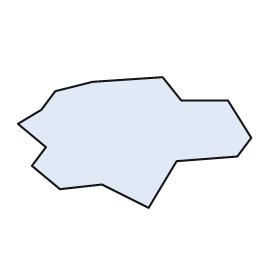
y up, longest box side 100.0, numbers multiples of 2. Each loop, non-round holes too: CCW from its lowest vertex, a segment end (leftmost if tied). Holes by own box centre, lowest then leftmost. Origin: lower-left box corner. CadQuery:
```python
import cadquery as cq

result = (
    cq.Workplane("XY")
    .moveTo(56.0, 0.0)
    .lineTo(68.0, 20.0)
    .lineTo(94.0, 22.0)
    .lineTo(100.0, 30.0)
    .lineTo(90.0, 46.0)
    .lineTo(70.0, 46.0)
    .lineTo(62.0, 56.0)
    .lineTo(32.0, 54.0)
    .lineTo(16.0, 50.0)
    .lineTo(10.0, 42.0)
    .lineTo(0.0, 36.0)
    .lineTo(12.0, 26.0)
    .lineTo(6.0, 18.0)
    .lineTo(18.0, 8.0)
    .lineTo(36.0, 10.0)
    .close()
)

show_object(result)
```